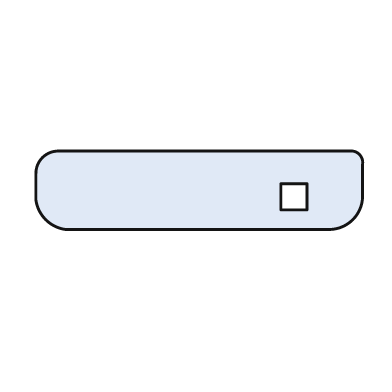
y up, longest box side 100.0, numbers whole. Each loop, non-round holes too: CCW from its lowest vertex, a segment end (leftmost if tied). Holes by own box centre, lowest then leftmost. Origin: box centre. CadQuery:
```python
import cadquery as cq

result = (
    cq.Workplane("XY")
    .moveTo(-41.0, -12.0)
    .lineTo(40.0, -12.0)
    .threePointArc((47.0, -9.0), (50.0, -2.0))
    .lineTo(50.0, 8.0)
    .threePointArc((49.0, 11.0), (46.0, 12.0))
    .lineTo(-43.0, 12.0)
    .threePointArc((-48.0, 10.0), (-50.0, 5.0))
    .lineTo(-50.0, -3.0)
    .threePointArc((-47.0, -9.0), (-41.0, -12.0))
    .close()
    .moveTo(25.0, -6.0)
    .lineTo(33.0, -6.0)
    .lineTo(33.0, 2.0)
    .lineTo(25.0, 2.0)
    .close()
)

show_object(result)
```